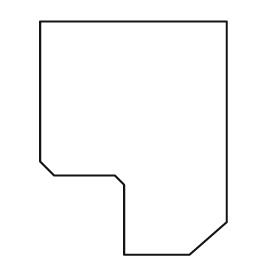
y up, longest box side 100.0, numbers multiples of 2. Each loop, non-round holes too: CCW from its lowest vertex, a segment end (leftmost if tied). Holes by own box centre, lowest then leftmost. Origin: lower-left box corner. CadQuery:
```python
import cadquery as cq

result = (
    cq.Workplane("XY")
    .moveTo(36.0, 0.0)
    .lineTo(64.0, 0.0)
    .lineTo(80.0, 14.0)
    .lineTo(80.0, 100.0)
    .lineTo(0.0, 100.0)
    .lineTo(0.0, 40.0)
    .lineTo(6.0, 34.0)
    .lineTo(32.0, 34.0)
    .lineTo(36.0, 30.0)
    .close()
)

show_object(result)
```